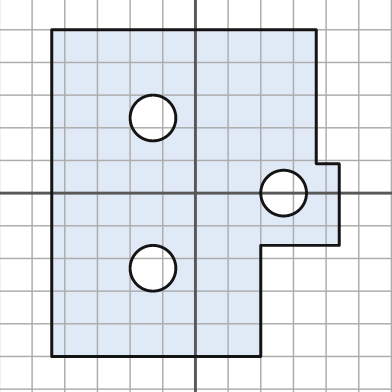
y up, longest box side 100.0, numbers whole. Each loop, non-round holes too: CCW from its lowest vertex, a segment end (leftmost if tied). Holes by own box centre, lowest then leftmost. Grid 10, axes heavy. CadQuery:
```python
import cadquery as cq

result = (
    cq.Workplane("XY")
    .moveTo(-44.0, -50.0)
    .lineTo(20.0, -50.0)
    .lineTo(20.0, -16.0)
    .lineTo(44.0, -16.0)
    .lineTo(44.0, 9.0)
    .lineTo(37.0, 9.0)
    .lineTo(37.0, 50.0)
    .lineTo(-44.0, 50.0)
    .close()
    .moveTo(-13.0, -23.0)
    .circle(7.0)
    .moveTo(27.0, 0.0)
    .circle(7.0)
    .moveTo(-13.0, 23.0)
    .circle(7.0)
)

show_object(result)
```